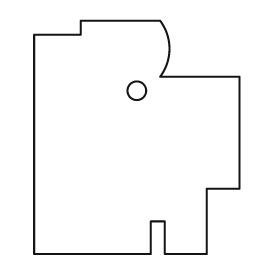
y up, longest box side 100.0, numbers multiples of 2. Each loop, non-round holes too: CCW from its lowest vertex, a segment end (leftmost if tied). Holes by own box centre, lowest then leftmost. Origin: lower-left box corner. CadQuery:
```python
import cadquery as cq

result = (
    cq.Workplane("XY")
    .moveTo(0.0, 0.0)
    .lineTo(50.0, 0.0)
    .lineTo(50.0, 14.0)
    .lineTo(56.0, 14.0)
    .lineTo(56.0, 0.0)
    .lineTo(74.0, 0.0)
    .lineTo(74.0, 28.0)
    .lineTo(88.0, 28.0)
    .lineTo(88.0, 76.0)
    .lineTo(54.0, 76.0)
    .threePointArc((58.0, 88.0), (54.0, 100.0))
    .lineTo(20.0, 100.0)
    .lineTo(20.0, 94.0)
    .lineTo(0.0, 94.0)
    .close()
    .moveTo(44.0, 70.0)
    .circle(4.0)
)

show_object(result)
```